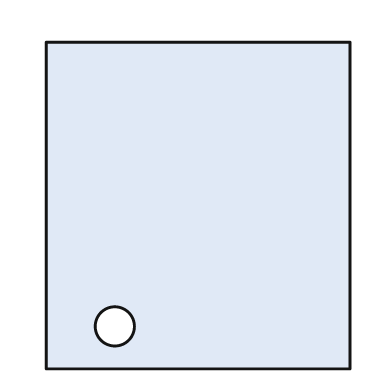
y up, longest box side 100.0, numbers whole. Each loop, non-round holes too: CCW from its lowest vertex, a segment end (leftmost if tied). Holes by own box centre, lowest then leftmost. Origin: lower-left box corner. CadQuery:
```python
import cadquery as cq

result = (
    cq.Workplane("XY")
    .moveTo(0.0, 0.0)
    .lineTo(93.0, 0.0)
    .lineTo(93.0, 100.0)
    .lineTo(0.0, 100.0)
    .close()
    .moveTo(21.0, 13.0)
    .circle(6.0)
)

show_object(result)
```